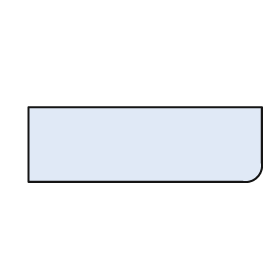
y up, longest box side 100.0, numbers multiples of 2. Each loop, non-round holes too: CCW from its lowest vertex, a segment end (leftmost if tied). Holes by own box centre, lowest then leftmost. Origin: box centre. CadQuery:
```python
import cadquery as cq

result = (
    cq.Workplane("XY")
    .moveTo(-50.0, -16.0)
    .lineTo(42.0, -16.0)
    .threePointArc((48.0, -14.0), (50.0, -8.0))
    .lineTo(50.0, 16.0)
    .lineTo(-50.0, 16.0)
    .close()
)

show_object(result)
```